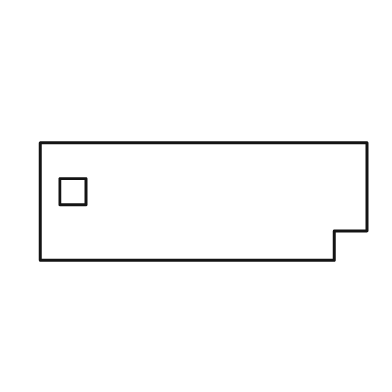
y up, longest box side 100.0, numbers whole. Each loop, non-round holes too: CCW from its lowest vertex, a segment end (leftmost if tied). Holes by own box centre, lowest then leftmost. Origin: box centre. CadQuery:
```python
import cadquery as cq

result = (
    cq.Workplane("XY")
    .moveTo(-50.0, -18.0)
    .lineTo(40.0, -18.0)
    .lineTo(40.0, -9.0)
    .lineTo(50.0, -9.0)
    .lineTo(50.0, 18.0)
    .lineTo(-50.0, 18.0)
    .close()
    .moveTo(-44.0, -1.0)
    .lineTo(-36.0, -1.0)
    .lineTo(-36.0, 7.0)
    .lineTo(-44.0, 7.0)
    .close()
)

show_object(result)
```